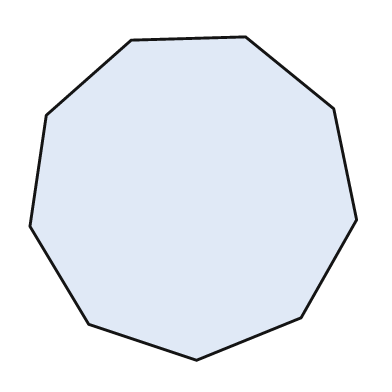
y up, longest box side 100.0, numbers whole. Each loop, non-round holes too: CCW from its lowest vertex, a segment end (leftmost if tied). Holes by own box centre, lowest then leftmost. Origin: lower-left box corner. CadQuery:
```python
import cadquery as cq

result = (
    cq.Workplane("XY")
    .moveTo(51.0, 0.0)
    .lineTo(83.0, 13.0)
    .lineTo(100.0, 43.0)
    .lineTo(93.0, 77.0)
    .lineTo(66.0, 99.0)
    .lineTo(31.0, 98.0)
    .lineTo(5.0, 75.0)
    .lineTo(0.0, 41.0)
    .lineTo(18.0, 11.0)
    .close()
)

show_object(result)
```